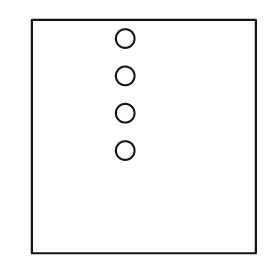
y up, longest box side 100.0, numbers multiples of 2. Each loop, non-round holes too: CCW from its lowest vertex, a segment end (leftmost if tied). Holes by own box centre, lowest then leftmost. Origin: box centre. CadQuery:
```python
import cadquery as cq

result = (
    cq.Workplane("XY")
    .moveTo(-48.0, -50.0)
    .lineTo(48.0, -50.0)
    .lineTo(48.0, 50.0)
    .lineTo(-48.0, 50.0)
    .close()
    .moveTo(-8.0, -6.0)
    .circle(4.0)
    .moveTo(-8.0, 10.0)
    .circle(4.0)
    .moveTo(-8.0, 26.0)
    .circle(4.0)
    .moveTo(-8.0, 42.0)
    .circle(4.0)
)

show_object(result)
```